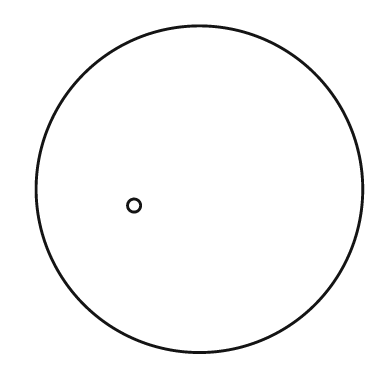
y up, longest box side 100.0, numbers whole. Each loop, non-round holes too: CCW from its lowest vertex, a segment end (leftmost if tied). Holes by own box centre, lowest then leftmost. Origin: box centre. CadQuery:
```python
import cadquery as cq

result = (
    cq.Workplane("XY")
    .moveTo(0.0, 0.0)
    .circle(50.0)
    .moveTo(-20.0, -5.0)
    .circle(2.0)
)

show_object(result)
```